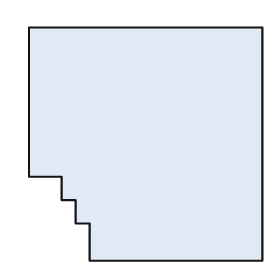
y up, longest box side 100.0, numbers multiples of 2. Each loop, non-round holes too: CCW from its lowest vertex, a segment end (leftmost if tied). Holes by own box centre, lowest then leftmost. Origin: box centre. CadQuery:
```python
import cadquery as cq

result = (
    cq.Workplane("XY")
    .moveTo(-24.0, -50.0)
    .lineTo(50.0, -50.0)
    .lineTo(50.0, 50.0)
    .lineTo(-50.0, 50.0)
    .lineTo(-50.0, -14.0)
    .lineTo(-36.0, -14.0)
    .lineTo(-36.0, -24.0)
    .lineTo(-30.0, -24.0)
    .lineTo(-30.0, -34.0)
    .lineTo(-24.0, -34.0)
    .close()
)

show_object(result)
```